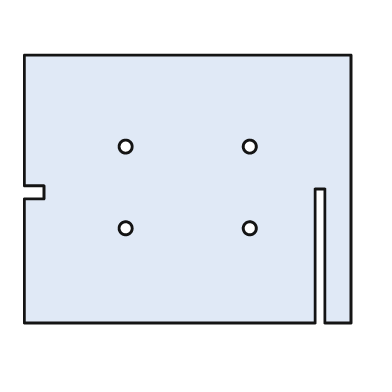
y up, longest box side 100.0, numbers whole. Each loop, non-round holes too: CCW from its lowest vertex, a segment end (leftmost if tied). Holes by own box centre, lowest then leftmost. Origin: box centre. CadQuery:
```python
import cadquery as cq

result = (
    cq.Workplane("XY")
    .moveTo(-50.0, -41.0)
    .lineTo(39.0, -41.0)
    .lineTo(39.0, 0.0)
    .lineTo(42.0, 0.0)
    .lineTo(42.0, -41.0)
    .lineTo(50.0, -41.0)
    .lineTo(50.0, 41.0)
    .lineTo(-50.0, 41.0)
    .lineTo(-50.0, 1.0)
    .lineTo(-44.0, 1.0)
    .lineTo(-44.0, -3.0)
    .lineTo(-50.0, -3.0)
    .close()
    .moveTo(-19.0, -12.0)
    .circle(2.0)
    .moveTo(19.0, -12.0)
    .circle(2.0)
    .moveTo(-19.0, 13.0)
    .circle(2.0)
    .moveTo(19.0, 13.0)
    .circle(2.0)
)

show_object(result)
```